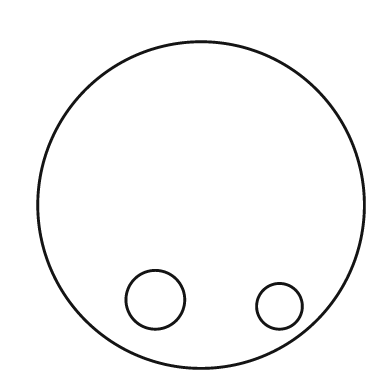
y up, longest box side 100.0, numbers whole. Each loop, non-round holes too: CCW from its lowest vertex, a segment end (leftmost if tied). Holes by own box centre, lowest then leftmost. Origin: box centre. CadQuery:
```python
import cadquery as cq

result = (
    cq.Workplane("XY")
    .moveTo(0.0, 0.0)
    .circle(50.0)
    .moveTo(24.0, -31.0)
    .circle(7.0)
    .moveTo(-14.0, -29.0)
    .circle(9.0)
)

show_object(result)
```